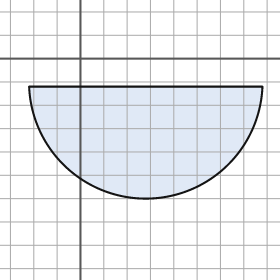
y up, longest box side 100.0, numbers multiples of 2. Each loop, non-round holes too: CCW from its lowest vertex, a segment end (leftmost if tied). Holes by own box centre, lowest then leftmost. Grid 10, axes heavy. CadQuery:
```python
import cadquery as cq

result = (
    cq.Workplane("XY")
    .moveTo(-22.0, -12.0)
    .threePointArc((28.0, -60.0), (78.0, -12.0))
    .close()
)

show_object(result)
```